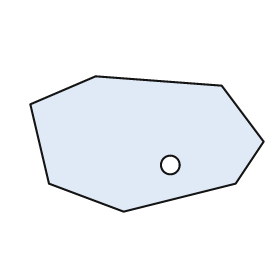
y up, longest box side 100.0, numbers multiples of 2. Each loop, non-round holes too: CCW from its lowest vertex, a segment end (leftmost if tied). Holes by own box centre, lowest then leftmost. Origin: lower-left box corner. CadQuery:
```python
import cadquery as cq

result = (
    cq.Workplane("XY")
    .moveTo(40.0, 0.0)
    .lineTo(88.0, 12.0)
    .lineTo(100.0, 30.0)
    .lineTo(82.0, 54.0)
    .lineTo(28.0, 58.0)
    .lineTo(0.0, 46.0)
    .lineTo(8.0, 12.0)
    .close()
    .moveTo(60.0, 20.0)
    .circle(4.0)
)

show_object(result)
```